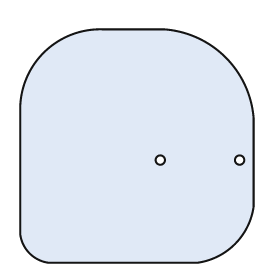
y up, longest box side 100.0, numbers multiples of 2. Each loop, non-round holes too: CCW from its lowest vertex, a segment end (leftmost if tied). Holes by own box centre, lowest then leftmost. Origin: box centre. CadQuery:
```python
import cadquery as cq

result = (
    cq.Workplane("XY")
    .moveTo(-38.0, -50.0)
    .lineTo(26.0, -50.0)
    .threePointArc((42.0, -42.0), (50.0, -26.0))
    .lineTo(50.0, 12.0)
    .threePointArc((38.0, 38.0), (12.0, 50.0))
    .lineTo(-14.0, 50.0)
    .threePointArc((-40.0, 40.0), (-50.0, 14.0))
    .lineTo(-50.0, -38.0)
    .threePointArc((-46.0, -46.0), (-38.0, -50.0))
    .close()
    .moveTo(10.0, -6.0)
    .circle(2.0)
    .moveTo(44.0, -6.0)
    .circle(2.0)
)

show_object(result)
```